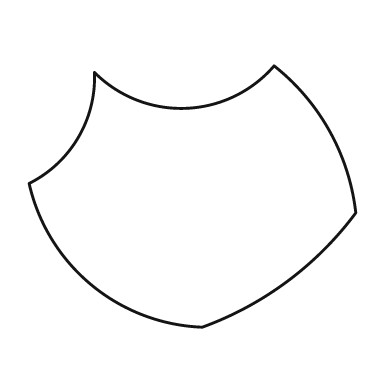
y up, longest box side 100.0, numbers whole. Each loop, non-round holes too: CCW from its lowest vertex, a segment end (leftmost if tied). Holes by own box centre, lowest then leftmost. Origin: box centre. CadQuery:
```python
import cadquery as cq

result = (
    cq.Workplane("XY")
    .moveTo(3.0, -40.0)
    .threePointArc((29.0, -26.0), (50.0, -5.0))
    .threePointArc((42.0, 20.0), (25.0, 40.0))
    .threePointArc((-2.0, 27.0), (-30.0, 38.0))
    .threePointArc((-35.0, 18.0), (-50.0, 4.0))
    .threePointArc((-31.0, -27.0), (3.0, -40.0))
    .close()
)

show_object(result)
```